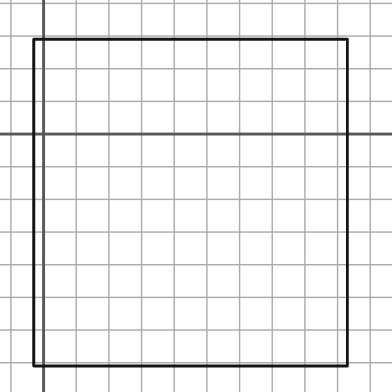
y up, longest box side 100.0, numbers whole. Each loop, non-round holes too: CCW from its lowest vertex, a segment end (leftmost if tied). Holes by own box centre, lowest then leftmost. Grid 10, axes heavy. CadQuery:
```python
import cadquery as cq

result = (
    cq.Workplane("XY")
    .moveTo(-3.0, -71.0)
    .lineTo(93.0, -71.0)
    .lineTo(93.0, 29.0)
    .lineTo(-3.0, 29.0)
    .close()
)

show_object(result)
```